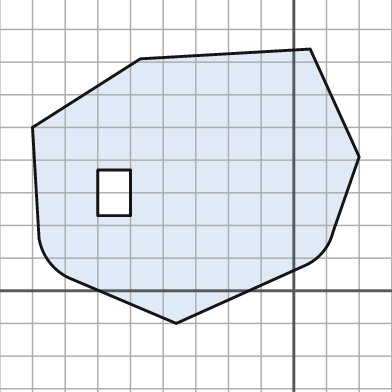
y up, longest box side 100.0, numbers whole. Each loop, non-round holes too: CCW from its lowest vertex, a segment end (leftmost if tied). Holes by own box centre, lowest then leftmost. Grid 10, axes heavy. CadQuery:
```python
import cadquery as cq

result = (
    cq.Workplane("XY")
    .moveTo(-36.0, -10.0)
    .lineTo(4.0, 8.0)
    .threePointArc((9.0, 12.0), (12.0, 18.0))
    .lineTo(20.0, 41.0)
    .lineTo(5.0, 74.0)
    .lineTo(-47.0, 71.0)
    .lineTo(-80.0, 50.0)
    .lineTo(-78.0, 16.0)
    .threePointArc((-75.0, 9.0), (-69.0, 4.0))
    .close()
    .moveTo(-60.0, 23.0)
    .lineTo(-50.0, 23.0)
    .lineTo(-50.0, 37.0)
    .lineTo(-60.0, 37.0)
    .close()
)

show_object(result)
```